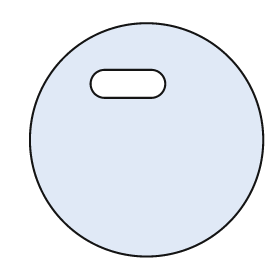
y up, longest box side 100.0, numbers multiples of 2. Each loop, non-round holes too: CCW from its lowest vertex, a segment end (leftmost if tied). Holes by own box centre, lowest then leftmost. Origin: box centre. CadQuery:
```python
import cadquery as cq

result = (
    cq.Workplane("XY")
    .moveTo(0.0, 0.0)
    .circle(50.0)
    .moveTo(-18.0, 18.0)
    .lineTo(2.0, 18.0)
    .threePointArc((8.0, 24.0), (2.0, 30.0))
    .lineTo(-18.0, 30.0)
    .threePointArc((-24.0, 24.0), (-18.0, 18.0))
    .close()
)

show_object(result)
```